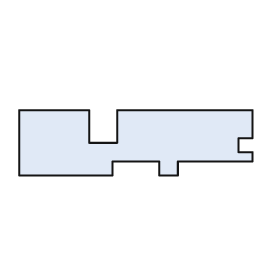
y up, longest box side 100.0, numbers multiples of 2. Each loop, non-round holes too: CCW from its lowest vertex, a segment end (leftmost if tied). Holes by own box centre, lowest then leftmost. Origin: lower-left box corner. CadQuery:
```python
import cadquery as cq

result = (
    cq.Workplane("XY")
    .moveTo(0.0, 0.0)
    .lineTo(40.0, 0.0)
    .lineTo(40.0, 6.0)
    .lineTo(60.0, 6.0)
    .lineTo(60.0, 0.0)
    .lineTo(68.0, 0.0)
    .lineTo(68.0, 6.0)
    .lineTo(100.0, 6.0)
    .lineTo(100.0, 10.0)
    .lineTo(94.0, 10.0)
    .lineTo(94.0, 16.0)
    .lineTo(100.0, 16.0)
    .lineTo(100.0, 28.0)
    .lineTo(42.0, 28.0)
    .lineTo(42.0, 14.0)
    .lineTo(30.0, 14.0)
    .lineTo(30.0, 28.0)
    .lineTo(0.0, 28.0)
    .close()
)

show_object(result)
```